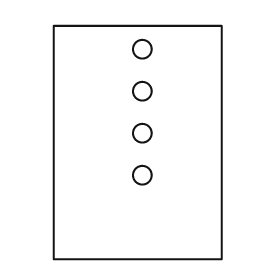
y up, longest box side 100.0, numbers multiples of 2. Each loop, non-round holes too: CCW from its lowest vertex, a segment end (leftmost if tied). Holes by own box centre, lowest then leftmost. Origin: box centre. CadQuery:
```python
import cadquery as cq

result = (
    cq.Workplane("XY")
    .moveTo(-36.0, -50.0)
    .lineTo(36.0, -50.0)
    .lineTo(36.0, 50.0)
    .lineTo(-36.0, 50.0)
    .close()
    .moveTo(2.0, -14.0)
    .circle(4.0)
    .moveTo(2.0, 4.0)
    .circle(4.0)
    .moveTo(2.0, 22.0)
    .circle(4.0)
    .moveTo(2.0, 40.0)
    .circle(4.0)
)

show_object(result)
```